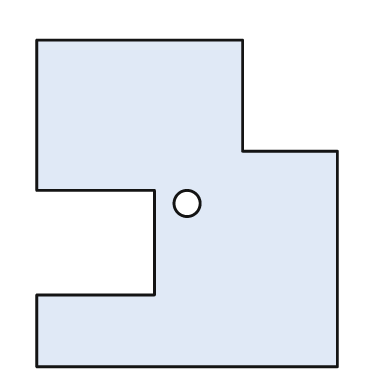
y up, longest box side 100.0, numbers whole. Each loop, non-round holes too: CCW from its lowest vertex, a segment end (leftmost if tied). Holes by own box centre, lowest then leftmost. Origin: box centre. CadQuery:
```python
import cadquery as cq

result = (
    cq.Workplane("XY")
    .moveTo(-46.0, -50.0)
    .lineTo(46.0, -50.0)
    .lineTo(46.0, 16.0)
    .lineTo(17.0, 16.0)
    .lineTo(17.0, 50.0)
    .lineTo(-46.0, 50.0)
    .lineTo(-46.0, 4.0)
    .lineTo(-10.0, 4.0)
    .lineTo(-10.0, -28.0)
    .lineTo(-46.0, -28.0)
    .close()
    .moveTo(0.0, 0.0)
    .circle(4.0)
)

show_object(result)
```